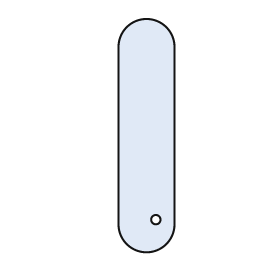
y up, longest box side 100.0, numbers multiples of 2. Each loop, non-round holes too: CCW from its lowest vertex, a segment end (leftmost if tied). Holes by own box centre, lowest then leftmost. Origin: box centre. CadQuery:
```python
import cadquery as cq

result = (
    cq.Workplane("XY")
    .moveTo(-12.0, -38.0)
    .threePointArc((0.0, -50.0), (12.0, -38.0))
    .lineTo(12.0, 38.0)
    .threePointArc((0.0, 50.0), (-12.0, 38.0))
    .close()
    .moveTo(4.0, -36.0)
    .circle(2.0)
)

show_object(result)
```